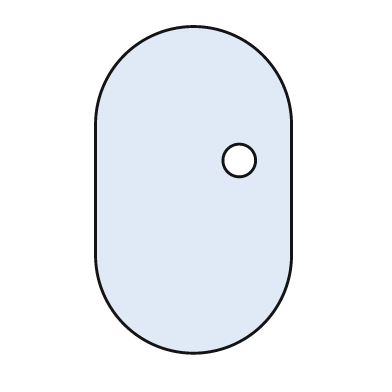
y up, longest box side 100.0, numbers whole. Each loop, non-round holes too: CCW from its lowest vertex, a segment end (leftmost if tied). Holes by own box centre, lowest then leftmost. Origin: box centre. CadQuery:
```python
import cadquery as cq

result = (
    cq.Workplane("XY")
    .moveTo(-30.0, -20.0)
    .threePointArc((0.0, -50.0), (30.0, -20.0))
    .lineTo(30.0, 20.0)
    .threePointArc((0.0, 50.0), (-30.0, 20.0))
    .close()
    .moveTo(14.0, 9.0)
    .circle(5.0)
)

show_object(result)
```